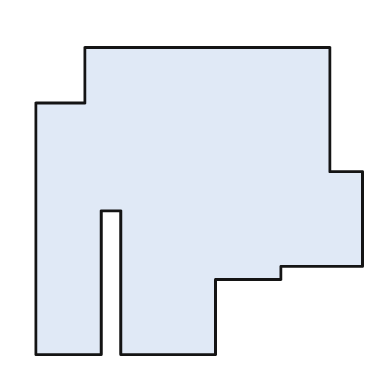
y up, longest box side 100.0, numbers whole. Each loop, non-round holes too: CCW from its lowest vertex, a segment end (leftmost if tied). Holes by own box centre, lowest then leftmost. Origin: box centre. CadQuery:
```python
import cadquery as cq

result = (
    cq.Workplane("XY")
    .moveTo(-50.0, -47.0)
    .lineTo(-30.0, -47.0)
    .lineTo(-30.0, -3.0)
    .lineTo(-24.0, -3.0)
    .lineTo(-24.0, -47.0)
    .lineTo(5.0, -47.0)
    .lineTo(5.0, -24.0)
    .lineTo(25.0, -24.0)
    .lineTo(25.0, -20.0)
    .lineTo(50.0, -20.0)
    .lineTo(50.0, 9.0)
    .lineTo(40.0, 9.0)
    .lineTo(40.0, 47.0)
    .lineTo(-35.0, 47.0)
    .lineTo(-35.0, 30.0)
    .lineTo(-50.0, 30.0)
    .close()
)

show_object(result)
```